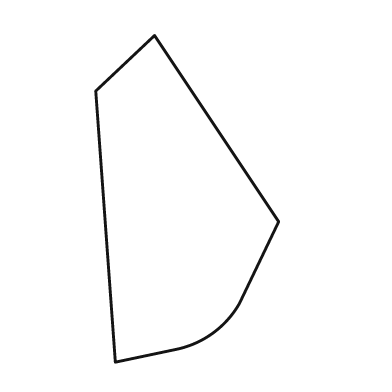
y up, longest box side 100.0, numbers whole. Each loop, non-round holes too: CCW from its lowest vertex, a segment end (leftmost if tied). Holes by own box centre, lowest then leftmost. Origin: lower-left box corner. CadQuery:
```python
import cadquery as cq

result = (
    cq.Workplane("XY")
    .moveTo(6.0, 0.0)
    .lineTo(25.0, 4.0)
    .threePointArc((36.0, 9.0), (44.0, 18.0))
    .lineTo(56.0, 43.0)
    .lineTo(18.0, 100.0)
    .lineTo(0.0, 83.0)
    .close()
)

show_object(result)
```